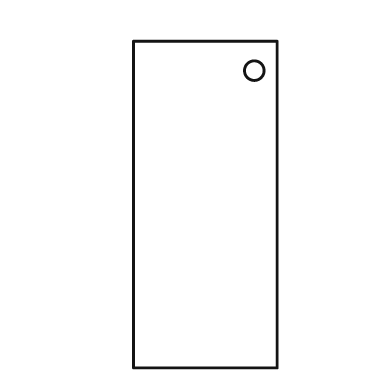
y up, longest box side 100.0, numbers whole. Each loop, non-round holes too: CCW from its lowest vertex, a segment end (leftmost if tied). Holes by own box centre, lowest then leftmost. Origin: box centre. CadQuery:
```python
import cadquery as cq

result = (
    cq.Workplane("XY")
    .moveTo(-22.0, -50.0)
    .lineTo(22.0, -50.0)
    .lineTo(22.0, 50.0)
    .lineTo(-22.0, 50.0)
    .close()
    .moveTo(15.0, 41.0)
    .circle(3.0)
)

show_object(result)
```